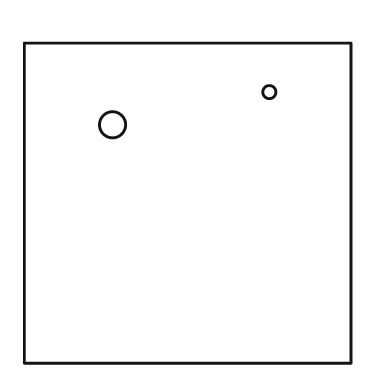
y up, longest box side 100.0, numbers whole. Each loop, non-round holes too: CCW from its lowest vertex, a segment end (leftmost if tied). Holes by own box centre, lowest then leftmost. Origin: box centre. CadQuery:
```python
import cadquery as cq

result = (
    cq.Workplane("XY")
    .moveTo(-50.0, -49.0)
    .lineTo(50.0, -49.0)
    .lineTo(50.0, 49.0)
    .lineTo(-50.0, 49.0)
    .close()
    .moveTo(-23.0, 24.0)
    .circle(4.0)
    .moveTo(25.0, 34.0)
    .circle(2.0)
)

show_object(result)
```